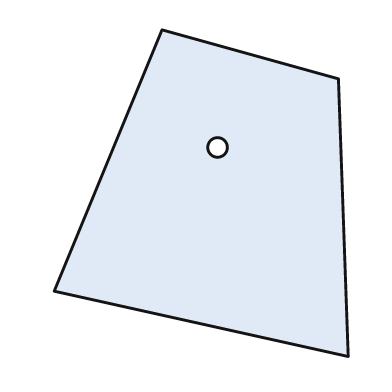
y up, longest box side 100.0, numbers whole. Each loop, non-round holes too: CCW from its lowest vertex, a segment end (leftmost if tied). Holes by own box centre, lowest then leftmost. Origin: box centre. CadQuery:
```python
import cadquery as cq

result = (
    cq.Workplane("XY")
    .moveTo(45.0, -50.0)
    .lineTo(42.0, 35.0)
    .lineTo(-12.0, 50.0)
    .lineTo(-45.0, -30.0)
    .close()
    .moveTo(5.0, 14.0)
    .circle(3.0)
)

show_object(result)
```